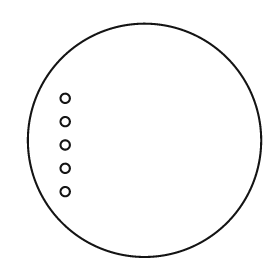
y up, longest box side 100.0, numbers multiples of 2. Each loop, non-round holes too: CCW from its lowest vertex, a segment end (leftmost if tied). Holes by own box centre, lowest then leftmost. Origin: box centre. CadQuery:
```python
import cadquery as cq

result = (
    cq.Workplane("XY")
    .moveTo(0.0, 0.0)
    .circle(50.0)
    .moveTo(-34.0, -22.0)
    .circle(2.0)
    .moveTo(-34.0, -12.0)
    .circle(2.0)
    .moveTo(-34.0, -2.0)
    .circle(2.0)
    .moveTo(-34.0, 8.0)
    .circle(2.0)
    .moveTo(-34.0, 18.0)
    .circle(2.0)
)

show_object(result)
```